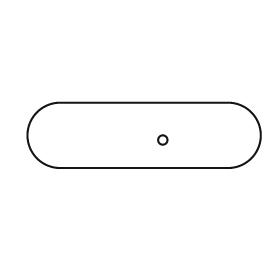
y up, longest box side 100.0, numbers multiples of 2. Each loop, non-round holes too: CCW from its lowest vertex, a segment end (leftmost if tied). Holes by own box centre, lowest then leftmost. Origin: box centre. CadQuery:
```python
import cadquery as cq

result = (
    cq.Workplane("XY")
    .moveTo(-36.0, -14.0)
    .lineTo(36.0, -14.0)
    .threePointArc((50.0, 0.0), (36.0, 14.0))
    .lineTo(-36.0, 14.0)
    .threePointArc((-50.0, 0.0), (-36.0, -14.0))
    .close()
    .moveTo(8.0, -2.0)
    .circle(2.0)
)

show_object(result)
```